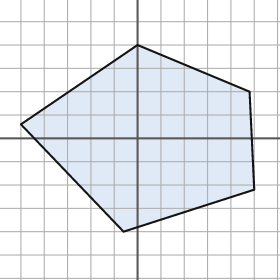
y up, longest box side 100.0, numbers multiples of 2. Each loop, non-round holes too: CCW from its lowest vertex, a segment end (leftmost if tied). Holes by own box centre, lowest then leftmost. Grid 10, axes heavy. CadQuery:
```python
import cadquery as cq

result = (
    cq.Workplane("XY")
    .moveTo(-6.0, -40.0)
    .lineTo(50.0, -22.0)
    .lineTo(48.0, 20.0)
    .lineTo(0.0, 40.0)
    .lineTo(-50.0, 6.0)
    .close()
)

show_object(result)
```